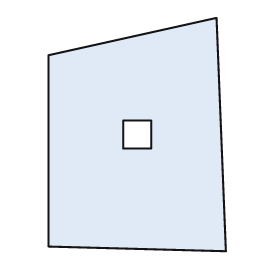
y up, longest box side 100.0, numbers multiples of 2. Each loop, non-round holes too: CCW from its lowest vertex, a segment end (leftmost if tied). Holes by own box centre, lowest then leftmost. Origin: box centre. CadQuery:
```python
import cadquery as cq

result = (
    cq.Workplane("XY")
    .moveTo(38.0, -50.0)
    .lineTo(34.0, 50.0)
    .lineTo(-38.0, 34.0)
    .lineTo(-38.0, -48.0)
    .close()
    .moveTo(-6.0, -6.0)
    .lineTo(6.0, -6.0)
    .lineTo(6.0, 6.0)
    .lineTo(-6.0, 6.0)
    .close()
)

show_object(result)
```